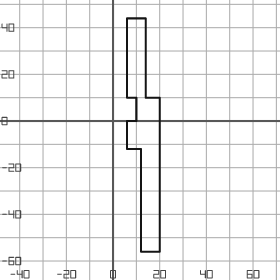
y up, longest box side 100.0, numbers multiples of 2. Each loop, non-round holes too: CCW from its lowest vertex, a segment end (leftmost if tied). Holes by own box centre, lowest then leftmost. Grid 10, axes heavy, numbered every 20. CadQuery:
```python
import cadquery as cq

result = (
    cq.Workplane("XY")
    .moveTo(12.0, -56.0)
    .lineTo(20.0, -56.0)
    .lineTo(20.0, 10.0)
    .lineTo(14.0, 10.0)
    .lineTo(14.0, 44.0)
    .lineTo(6.0, 44.0)
    .lineTo(6.0, 10.0)
    .lineTo(10.0, 10.0)
    .lineTo(10.0, 0.0)
    .lineTo(6.0, 0.0)
    .lineTo(6.0, -12.0)
    .lineTo(12.0, -12.0)
    .close()
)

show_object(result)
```